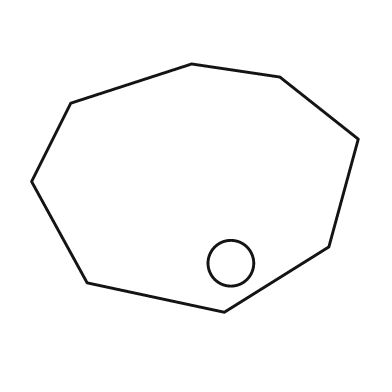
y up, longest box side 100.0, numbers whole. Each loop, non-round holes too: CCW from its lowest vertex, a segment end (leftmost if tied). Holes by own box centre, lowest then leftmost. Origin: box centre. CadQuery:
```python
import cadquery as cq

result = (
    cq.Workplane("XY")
    .moveTo(9.0, -38.0)
    .lineTo(41.0, -18.0)
    .lineTo(50.0, 15.0)
    .lineTo(26.0, 34.0)
    .lineTo(-1.0, 38.0)
    .lineTo(-38.0, 26.0)
    .lineTo(-50.0, 2.0)
    .lineTo(-33.0, -29.0)
    .close()
    .moveTo(11.0, -23.0)
    .circle(7.0)
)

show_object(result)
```